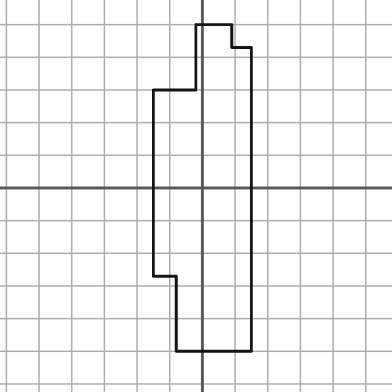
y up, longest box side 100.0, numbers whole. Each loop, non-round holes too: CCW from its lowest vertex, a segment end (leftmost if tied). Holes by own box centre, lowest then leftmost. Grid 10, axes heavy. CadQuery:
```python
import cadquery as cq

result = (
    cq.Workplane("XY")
    .moveTo(-8.0, -50.0)
    .lineTo(15.0, -50.0)
    .lineTo(15.0, 43.0)
    .lineTo(9.0, 43.0)
    .lineTo(9.0, 50.0)
    .lineTo(-2.0, 50.0)
    .lineTo(-2.0, 30.0)
    .lineTo(-15.0, 30.0)
    .lineTo(-15.0, -27.0)
    .lineTo(-8.0, -27.0)
    .close()
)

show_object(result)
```